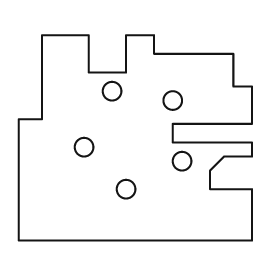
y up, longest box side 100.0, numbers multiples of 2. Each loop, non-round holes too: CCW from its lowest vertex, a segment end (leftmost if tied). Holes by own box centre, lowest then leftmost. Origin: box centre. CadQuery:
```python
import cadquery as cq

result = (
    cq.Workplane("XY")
    .moveTo(-50.0, -44.0)
    .lineTo(50.0, -44.0)
    .lineTo(50.0, -22.0)
    .lineTo(32.0, -22.0)
    .lineTo(32.0, -14.0)
    .lineTo(38.0, -8.0)
    .lineTo(50.0, -8.0)
    .lineTo(50.0, -2.0)
    .lineTo(16.0, -2.0)
    .lineTo(16.0, 6.0)
    .lineTo(50.0, 6.0)
    .lineTo(50.0, 22.0)
    .lineTo(42.0, 22.0)
    .lineTo(42.0, 36.0)
    .lineTo(8.0, 36.0)
    .lineTo(8.0, 44.0)
    .lineTo(-4.0, 44.0)
    .lineTo(-4.0, 28.0)
    .lineTo(-20.0, 28.0)
    .lineTo(-20.0, 44.0)
    .lineTo(-40.0, 44.0)
    .lineTo(-40.0, 8.0)
    .lineTo(-50.0, 8.0)
    .close()
    .moveTo(-4.0, -22.0)
    .circle(4.0)
    .moveTo(20.0, -10.0)
    .circle(4.0)
    .moveTo(-22.0, -4.0)
    .circle(4.0)
    .moveTo(16.0, 16.0)
    .circle(4.0)
    .moveTo(-10.0, 20.0)
    .circle(4.0)
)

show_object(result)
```